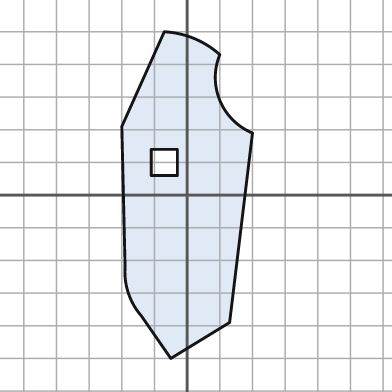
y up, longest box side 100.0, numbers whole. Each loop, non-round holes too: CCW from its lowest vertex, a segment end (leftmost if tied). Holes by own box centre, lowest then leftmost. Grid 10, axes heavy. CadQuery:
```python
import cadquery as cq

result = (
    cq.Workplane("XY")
    .moveTo(-5.0, -50.0)
    .lineTo(13.0, -39.0)
    .lineTo(20.0, 19.0)
    .threePointArc((10.0, 29.0), (10.0, 43.0))
    .threePointArc((2.0, 48.0), (-7.0, 50.0))
    .lineTo(-20.0, 21.0)
    .lineTo(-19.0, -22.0)
    .threePointArc((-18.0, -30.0), (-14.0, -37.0))
    .close()
    .moveTo(-11.0, 6.0)
    .lineTo(-3.0, 6.0)
    .lineTo(-3.0, 14.0)
    .lineTo(-11.0, 14.0)
    .close()
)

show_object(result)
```